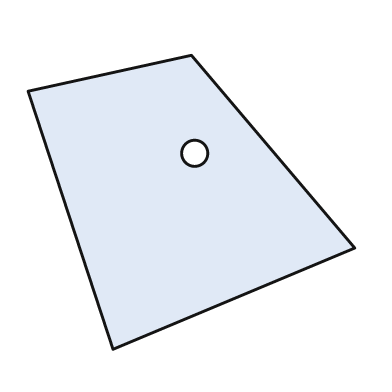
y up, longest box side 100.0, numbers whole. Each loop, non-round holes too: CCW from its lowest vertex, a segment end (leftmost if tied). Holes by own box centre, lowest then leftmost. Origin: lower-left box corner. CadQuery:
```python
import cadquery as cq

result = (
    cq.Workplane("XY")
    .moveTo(26.0, 0.0)
    .lineTo(100.0, 31.0)
    .lineTo(50.0, 90.0)
    .lineTo(0.0, 79.0)
    .close()
    .moveTo(51.0, 60.0)
    .circle(4.0)
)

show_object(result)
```